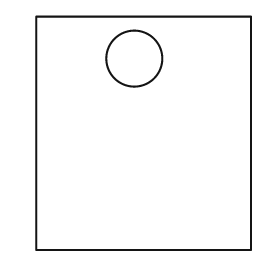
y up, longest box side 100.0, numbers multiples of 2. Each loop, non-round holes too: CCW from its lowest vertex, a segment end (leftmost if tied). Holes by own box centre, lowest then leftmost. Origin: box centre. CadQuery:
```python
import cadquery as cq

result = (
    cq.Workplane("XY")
    .moveTo(-46.0, -50.0)
    .lineTo(46.0, -50.0)
    .lineTo(46.0, 50.0)
    .lineTo(-46.0, 50.0)
    .close()
    .moveTo(-4.0, 32.0)
    .circle(12.0)
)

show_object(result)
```